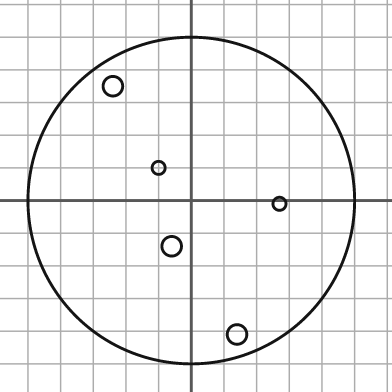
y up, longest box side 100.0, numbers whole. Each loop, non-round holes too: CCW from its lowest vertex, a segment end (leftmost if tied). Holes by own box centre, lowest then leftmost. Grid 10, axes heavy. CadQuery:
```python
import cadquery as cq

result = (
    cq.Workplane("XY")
    .moveTo(0.0, 0.0)
    .circle(50.0)
    .moveTo(14.0, -41.0)
    .circle(3.0)
    .moveTo(-6.0, -14.0)
    .circle(3.0)
    .moveTo(27.0, -1.0)
    .circle(2.0)
    .moveTo(-10.0, 10.0)
    .circle(2.0)
    .moveTo(-24.0, 35.0)
    .circle(3.0)
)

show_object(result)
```